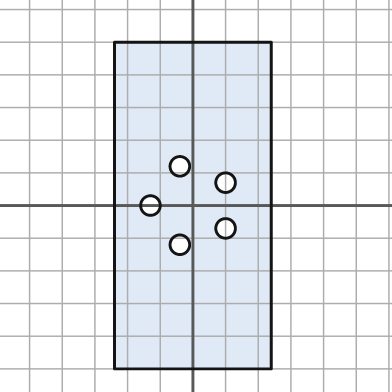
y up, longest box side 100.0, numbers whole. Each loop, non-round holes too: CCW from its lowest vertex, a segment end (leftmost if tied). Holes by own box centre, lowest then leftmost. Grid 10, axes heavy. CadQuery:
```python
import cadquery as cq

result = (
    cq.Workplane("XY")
    .moveTo(-24.0, -50.0)
    .lineTo(24.0, -50.0)
    .lineTo(24.0, 50.0)
    .lineTo(-24.0, 50.0)
    .close()
    .moveTo(-4.0, -12.0)
    .circle(3.0)
    .moveTo(10.0, -7.0)
    .circle(3.0)
    .moveTo(-13.0, 0.0)
    .circle(3.0)
    .moveTo(10.0, 7.0)
    .circle(3.0)
    .moveTo(-4.0, 12.0)
    .circle(3.0)
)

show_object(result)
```